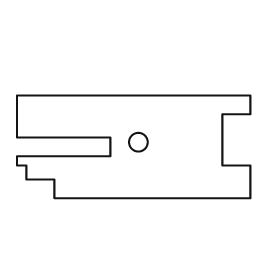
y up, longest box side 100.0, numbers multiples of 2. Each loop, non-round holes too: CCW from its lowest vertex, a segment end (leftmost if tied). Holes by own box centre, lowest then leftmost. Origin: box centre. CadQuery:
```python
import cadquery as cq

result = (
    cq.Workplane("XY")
    .moveTo(-34.0, -22.0)
    .lineTo(50.0, -22.0)
    .lineTo(50.0, -8.0)
    .lineTo(38.0, -8.0)
    .lineTo(38.0, 14.0)
    .lineTo(50.0, 14.0)
    .lineTo(50.0, 22.0)
    .lineTo(-50.0, 22.0)
    .lineTo(-50.0, 4.0)
    .lineTo(-10.0, 4.0)
    .lineTo(-10.0, -4.0)
    .lineTo(-50.0, -4.0)
    .lineTo(-50.0, -8.0)
    .lineTo(-46.0, -8.0)
    .lineTo(-46.0, -14.0)
    .lineTo(-34.0, -14.0)
    .close()
    .moveTo(2.0, 2.0)
    .circle(4.0)
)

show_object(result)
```